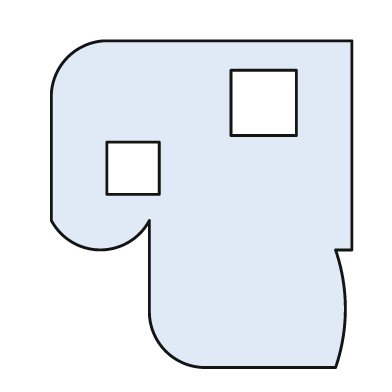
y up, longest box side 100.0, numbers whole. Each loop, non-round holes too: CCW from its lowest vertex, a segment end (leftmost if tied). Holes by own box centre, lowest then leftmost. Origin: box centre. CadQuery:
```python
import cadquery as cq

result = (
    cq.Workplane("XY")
    .moveTo(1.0, -50.0)
    .lineTo(41.0, -50.0)
    .threePointArc((44.0, -32.0), (41.0, -14.0))
    .lineTo(46.0, -14.0)
    .lineTo(46.0, 50.0)
    .lineTo(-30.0, 50.0)
    .threePointArc((-41.0, 45.0), (-46.0, 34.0))
    .lineTo(-46.0, -5.0)
    .threePointArc((-31.0, -14.0), (-16.0, -5.0))
    .lineTo(-16.0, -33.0)
    .threePointArc((-11.0, -45.0), (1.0, -50.0))
    .close()
    .moveTo(-29.0, 3.0)
    .lineTo(-13.0, 3.0)
    .lineTo(-13.0, 19.0)
    .lineTo(-29.0, 19.0)
    .close()
    .moveTo(9.0, 21.0)
    .lineTo(29.0, 21.0)
    .lineTo(29.0, 41.0)
    .lineTo(9.0, 41.0)
    .close()
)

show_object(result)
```